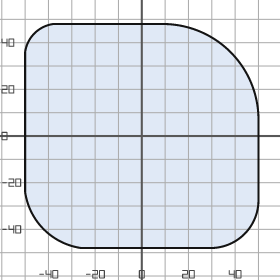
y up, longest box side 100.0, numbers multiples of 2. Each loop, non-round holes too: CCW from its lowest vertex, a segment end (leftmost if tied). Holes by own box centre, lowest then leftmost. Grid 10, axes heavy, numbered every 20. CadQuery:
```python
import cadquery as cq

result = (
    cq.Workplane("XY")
    .moveTo(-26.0, -48.0)
    .lineTo(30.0, -48.0)
    .threePointArc((44.0, -42.0), (50.0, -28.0))
    .lineTo(50.0, 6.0)
    .threePointArc((38.0, 36.0), (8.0, 48.0))
    .lineTo(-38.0, 48.0)
    .threePointArc((-46.0, 44.0), (-50.0, 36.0))
    .lineTo(-50.0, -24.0)
    .threePointArc((-42.0, -40.0), (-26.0, -48.0))
    .close()
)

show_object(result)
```